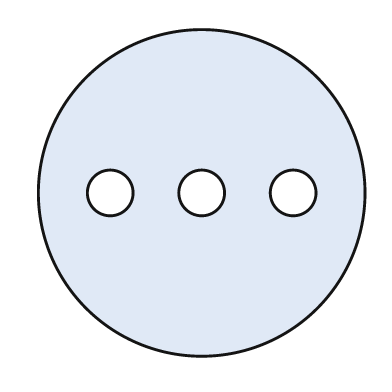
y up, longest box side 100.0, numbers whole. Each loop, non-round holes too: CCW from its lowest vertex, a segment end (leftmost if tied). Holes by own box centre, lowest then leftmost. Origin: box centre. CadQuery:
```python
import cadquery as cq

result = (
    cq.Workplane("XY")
    .moveTo(0.0, 0.0)
    .circle(50.0)
    .moveTo(-28.0, 0.0)
    .circle(7.0)
    .moveTo(0.0, 0.0)
    .circle(7.0)
    .moveTo(28.0, 0.0)
    .circle(7.0)
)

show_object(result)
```